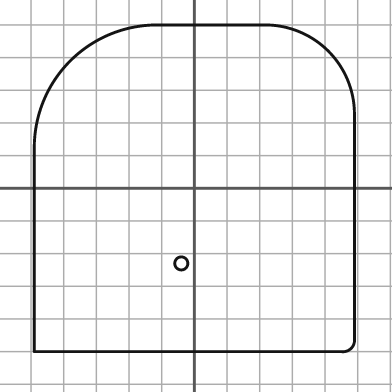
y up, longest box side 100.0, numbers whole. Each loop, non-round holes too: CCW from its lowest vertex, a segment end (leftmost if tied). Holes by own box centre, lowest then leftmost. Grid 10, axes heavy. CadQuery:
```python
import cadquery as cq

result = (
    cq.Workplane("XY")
    .moveTo(-49.0, -50.0)
    .lineTo(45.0, -50.0)
    .threePointArc((48.0, -49.0), (49.0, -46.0))
    .lineTo(49.0, 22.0)
    .threePointArc((41.0, 42.0), (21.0, 50.0))
    .lineTo(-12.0, 50.0)
    .threePointArc((-38.0, 39.0), (-49.0, 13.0))
    .close()
    .moveTo(-4.0, -23.0)
    .circle(2.0)
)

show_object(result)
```